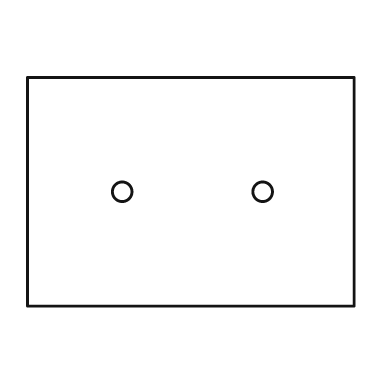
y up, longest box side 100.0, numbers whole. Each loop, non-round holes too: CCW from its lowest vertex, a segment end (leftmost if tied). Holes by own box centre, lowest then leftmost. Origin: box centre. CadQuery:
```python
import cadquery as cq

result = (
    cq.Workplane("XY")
    .moveTo(-50.0, -35.0)
    .lineTo(50.0, -35.0)
    .lineTo(50.0, 35.0)
    .lineTo(-50.0, 35.0)
    .close()
    .moveTo(-21.0, 0.0)
    .circle(3.0)
    .moveTo(22.0, 0.0)
    .circle(3.0)
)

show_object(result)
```